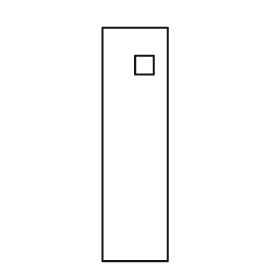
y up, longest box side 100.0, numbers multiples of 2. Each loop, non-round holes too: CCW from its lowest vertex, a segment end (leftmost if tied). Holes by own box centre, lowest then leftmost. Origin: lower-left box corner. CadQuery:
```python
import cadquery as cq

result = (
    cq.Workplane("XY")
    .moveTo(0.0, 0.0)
    .lineTo(28.0, 0.0)
    .lineTo(28.0, 100.0)
    .lineTo(0.0, 100.0)
    .close()
    .moveTo(14.0, 80.0)
    .lineTo(22.0, 80.0)
    .lineTo(22.0, 88.0)
    .lineTo(14.0, 88.0)
    .close()
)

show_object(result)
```